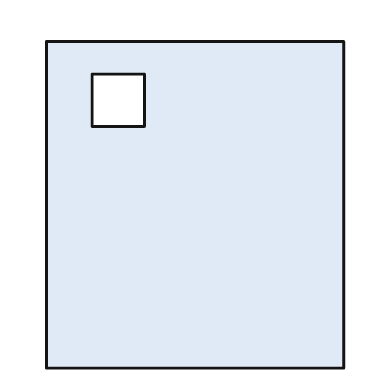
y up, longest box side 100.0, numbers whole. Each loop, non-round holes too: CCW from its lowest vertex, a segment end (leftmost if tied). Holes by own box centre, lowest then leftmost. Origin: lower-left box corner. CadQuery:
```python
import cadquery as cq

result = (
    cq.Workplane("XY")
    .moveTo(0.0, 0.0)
    .lineTo(91.0, 0.0)
    .lineTo(91.0, 100.0)
    .lineTo(0.0, 100.0)
    .close()
    .moveTo(14.0, 74.0)
    .lineTo(30.0, 74.0)
    .lineTo(30.0, 90.0)
    .lineTo(14.0, 90.0)
    .close()
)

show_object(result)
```